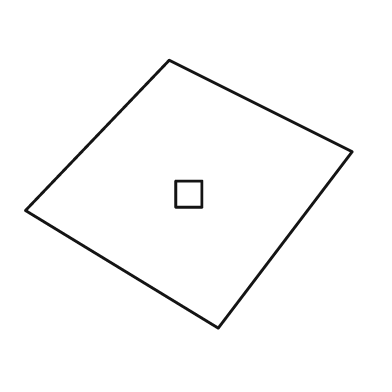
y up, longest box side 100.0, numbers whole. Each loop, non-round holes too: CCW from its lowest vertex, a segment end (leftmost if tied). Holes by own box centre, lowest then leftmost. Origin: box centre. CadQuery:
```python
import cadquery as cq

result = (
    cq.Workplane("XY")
    .moveTo(9.0, -41.0)
    .lineTo(50.0, 13.0)
    .lineTo(-6.0, 41.0)
    .lineTo(-50.0, -5.0)
    .close()
    .moveTo(-4.0, -4.0)
    .lineTo(4.0, -4.0)
    .lineTo(4.0, 4.0)
    .lineTo(-4.0, 4.0)
    .close()
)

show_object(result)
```